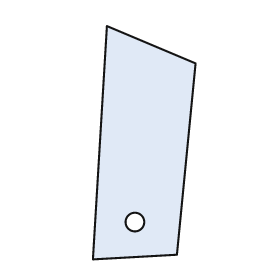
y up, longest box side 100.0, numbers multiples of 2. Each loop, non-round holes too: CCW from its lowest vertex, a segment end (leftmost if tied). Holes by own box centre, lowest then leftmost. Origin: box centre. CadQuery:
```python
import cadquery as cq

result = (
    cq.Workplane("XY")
    .moveTo(-22.0, -50.0)
    .lineTo(14.0, -48.0)
    .lineTo(22.0, 34.0)
    .lineTo(-16.0, 50.0)
    .close()
    .moveTo(-4.0, -34.0)
    .circle(4.0)
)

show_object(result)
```